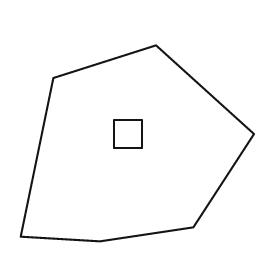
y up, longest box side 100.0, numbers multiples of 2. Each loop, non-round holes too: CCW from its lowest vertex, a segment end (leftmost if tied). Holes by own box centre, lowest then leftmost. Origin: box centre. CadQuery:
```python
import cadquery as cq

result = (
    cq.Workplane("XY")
    .moveTo(-16.0, -42.0)
    .lineTo(24.0, -36.0)
    .lineTo(50.0, 4.0)
    .lineTo(8.0, 42.0)
    .lineTo(-36.0, 28.0)
    .lineTo(-50.0, -40.0)
    .close()
    .moveTo(-10.0, -2.0)
    .lineTo(2.0, -2.0)
    .lineTo(2.0, 10.0)
    .lineTo(-10.0, 10.0)
    .close()
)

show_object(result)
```